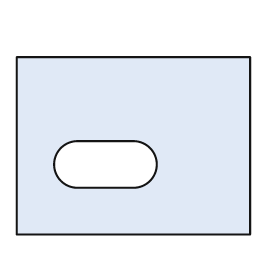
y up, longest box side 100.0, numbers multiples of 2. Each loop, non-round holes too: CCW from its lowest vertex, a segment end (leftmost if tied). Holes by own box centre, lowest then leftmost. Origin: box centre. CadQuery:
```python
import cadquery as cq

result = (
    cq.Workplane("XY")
    .moveTo(-50.0, -38.0)
    .lineTo(50.0, -38.0)
    .lineTo(50.0, 38.0)
    .lineTo(-50.0, 38.0)
    .close()
    .moveTo(-24.0, -18.0)
    .lineTo(0.0, -18.0)
    .threePointArc((10.0, -8.0), (0.0, 2.0))
    .lineTo(-24.0, 2.0)
    .threePointArc((-34.0, -8.0), (-24.0, -18.0))
    .close()
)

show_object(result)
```